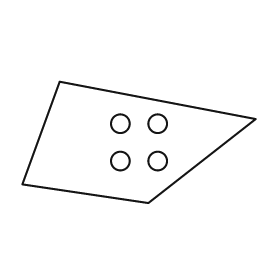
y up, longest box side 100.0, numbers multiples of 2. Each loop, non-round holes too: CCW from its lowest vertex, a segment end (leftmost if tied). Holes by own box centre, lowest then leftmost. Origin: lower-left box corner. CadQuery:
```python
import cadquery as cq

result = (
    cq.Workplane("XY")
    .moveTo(54.0, 0.0)
    .lineTo(100.0, 36.0)
    .lineTo(16.0, 52.0)
    .lineTo(0.0, 8.0)
    .close()
    .moveTo(42.0, 18.0)
    .circle(4.0)
    .moveTo(58.0, 18.0)
    .circle(4.0)
    .moveTo(42.0, 34.0)
    .circle(4.0)
    .moveTo(58.0, 34.0)
    .circle(4.0)
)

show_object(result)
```